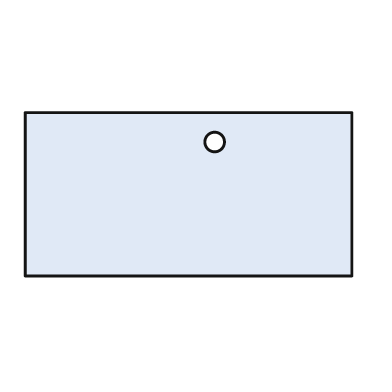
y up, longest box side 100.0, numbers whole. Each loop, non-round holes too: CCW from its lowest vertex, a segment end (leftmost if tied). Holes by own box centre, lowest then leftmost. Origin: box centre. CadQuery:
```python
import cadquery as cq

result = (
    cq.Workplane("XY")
    .moveTo(-50.0, -25.0)
    .lineTo(50.0, -25.0)
    .lineTo(50.0, 25.0)
    .lineTo(-50.0, 25.0)
    .close()
    .moveTo(8.0, 16.0)
    .circle(3.0)
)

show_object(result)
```